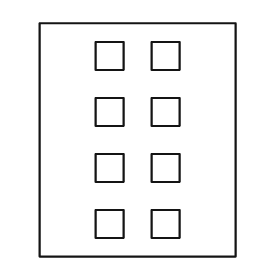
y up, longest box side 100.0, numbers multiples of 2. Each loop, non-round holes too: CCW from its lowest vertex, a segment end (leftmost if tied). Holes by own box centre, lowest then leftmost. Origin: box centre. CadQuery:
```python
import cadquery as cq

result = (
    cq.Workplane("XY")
    .moveTo(-42.0, -50.0)
    .lineTo(42.0, -50.0)
    .lineTo(42.0, 50.0)
    .lineTo(-42.0, 50.0)
    .close()
    .moveTo(-18.0, -42.0)
    .lineTo(-6.0, -42.0)
    .lineTo(-6.0, -30.0)
    .lineTo(-18.0, -30.0)
    .close()
    .moveTo(6.0, -42.0)
    .lineTo(18.0, -42.0)
    .lineTo(18.0, -30.0)
    .lineTo(6.0, -30.0)
    .close()
    .moveTo(-18.0, -18.0)
    .lineTo(-6.0, -18.0)
    .lineTo(-6.0, -6.0)
    .lineTo(-18.0, -6.0)
    .close()
    .moveTo(6.0, -18.0)
    .lineTo(18.0, -18.0)
    .lineTo(18.0, -6.0)
    .lineTo(6.0, -6.0)
    .close()
    .moveTo(-18.0, 6.0)
    .lineTo(-6.0, 6.0)
    .lineTo(-6.0, 18.0)
    .lineTo(-18.0, 18.0)
    .close()
    .moveTo(6.0, 6.0)
    .lineTo(18.0, 6.0)
    .lineTo(18.0, 18.0)
    .lineTo(6.0, 18.0)
    .close()
    .moveTo(-18.0, 30.0)
    .lineTo(-6.0, 30.0)
    .lineTo(-6.0, 42.0)
    .lineTo(-18.0, 42.0)
    .close()
    .moveTo(6.0, 30.0)
    .lineTo(18.0, 30.0)
    .lineTo(18.0, 42.0)
    .lineTo(6.0, 42.0)
    .close()
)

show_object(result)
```